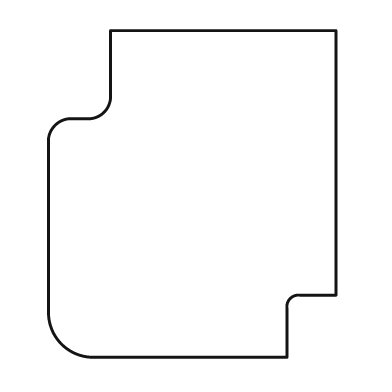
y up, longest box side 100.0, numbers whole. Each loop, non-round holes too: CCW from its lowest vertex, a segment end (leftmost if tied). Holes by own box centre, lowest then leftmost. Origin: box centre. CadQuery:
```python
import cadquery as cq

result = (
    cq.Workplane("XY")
    .moveTo(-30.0, -50.0)
    .lineTo(29.0, -50.0)
    .lineTo(29.0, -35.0)
    .threePointArc((30.0, -32.0), (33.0, -31.0))
    .lineTo(44.0, -31.0)
    .lineTo(44.0, 50.0)
    .lineTo(-25.0, 50.0)
    .lineTo(-25.0, 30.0)
    .threePointArc((-27.0, 25.0), (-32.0, 23.0))
    .lineTo(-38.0, 23.0)
    .threePointArc((-42.0, 21.0), (-44.0, 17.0))
    .lineTo(-44.0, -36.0)
    .threePointArc((-40.0, -46.0), (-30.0, -50.0))
    .close()
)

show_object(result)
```